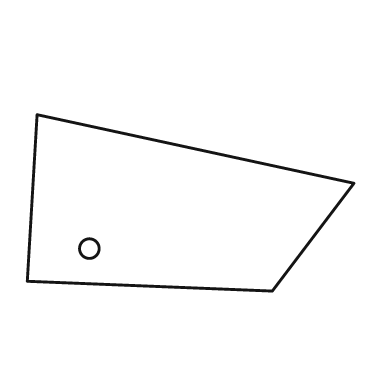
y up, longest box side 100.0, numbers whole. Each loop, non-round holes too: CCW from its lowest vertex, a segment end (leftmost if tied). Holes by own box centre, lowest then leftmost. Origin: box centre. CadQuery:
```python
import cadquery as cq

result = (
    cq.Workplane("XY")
    .moveTo(25.0, -27.0)
    .lineTo(50.0, 6.0)
    .lineTo(-47.0, 27.0)
    .lineTo(-50.0, -24.0)
    .close()
    .moveTo(-31.0, -14.0)
    .circle(3.0)
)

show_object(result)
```